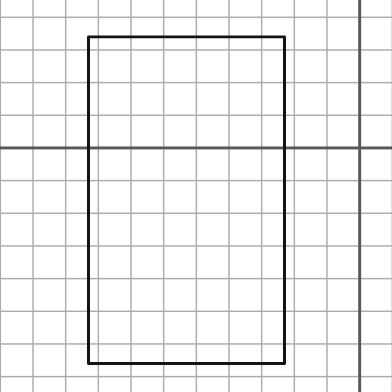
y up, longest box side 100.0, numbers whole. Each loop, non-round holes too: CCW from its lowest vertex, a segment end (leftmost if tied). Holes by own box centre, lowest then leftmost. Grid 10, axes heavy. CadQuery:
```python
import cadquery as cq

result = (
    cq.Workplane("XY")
    .moveTo(-83.0, -66.0)
    .lineTo(-23.0, -66.0)
    .lineTo(-23.0, 34.0)
    .lineTo(-83.0, 34.0)
    .close()
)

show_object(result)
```